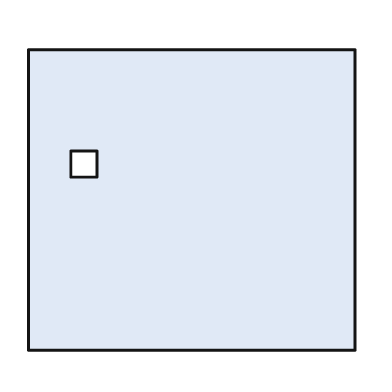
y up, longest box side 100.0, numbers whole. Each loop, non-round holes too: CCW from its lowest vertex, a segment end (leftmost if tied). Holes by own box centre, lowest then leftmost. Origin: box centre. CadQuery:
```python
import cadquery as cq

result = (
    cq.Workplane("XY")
    .moveTo(-50.0, -46.0)
    .lineTo(50.0, -46.0)
    .lineTo(50.0, 46.0)
    .lineTo(-50.0, 46.0)
    .close()
    .moveTo(-37.0, 7.0)
    .lineTo(-29.0, 7.0)
    .lineTo(-29.0, 15.0)
    .lineTo(-37.0, 15.0)
    .close()
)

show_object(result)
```